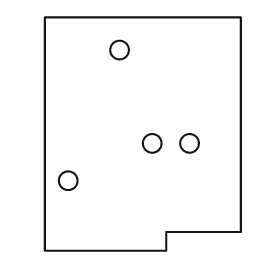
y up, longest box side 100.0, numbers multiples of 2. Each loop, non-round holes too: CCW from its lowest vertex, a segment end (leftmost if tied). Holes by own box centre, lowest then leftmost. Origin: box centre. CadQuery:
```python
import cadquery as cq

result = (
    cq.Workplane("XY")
    .moveTo(-42.0, -50.0)
    .lineTo(10.0, -50.0)
    .lineTo(10.0, -42.0)
    .lineTo(42.0, -42.0)
    .lineTo(42.0, 50.0)
    .lineTo(-42.0, 50.0)
    .close()
    .moveTo(-32.0, -20.0)
    .circle(4.0)
    .moveTo(4.0, -4.0)
    .circle(4.0)
    .moveTo(20.0, -4.0)
    .circle(4.0)
    .moveTo(-10.0, 36.0)
    .circle(4.0)
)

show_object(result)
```